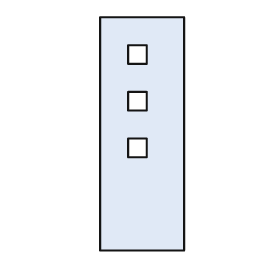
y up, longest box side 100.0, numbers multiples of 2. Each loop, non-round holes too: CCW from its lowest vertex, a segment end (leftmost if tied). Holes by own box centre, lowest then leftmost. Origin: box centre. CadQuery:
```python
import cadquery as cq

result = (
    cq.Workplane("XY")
    .moveTo(-18.0, -50.0)
    .lineTo(18.0, -50.0)
    .lineTo(18.0, 50.0)
    .lineTo(-18.0, 50.0)
    .close()
    .moveTo(-6.0, -10.0)
    .lineTo(2.0, -10.0)
    .lineTo(2.0, -2.0)
    .lineTo(-6.0, -2.0)
    .close()
    .moveTo(-6.0, 10.0)
    .lineTo(2.0, 10.0)
    .lineTo(2.0, 18.0)
    .lineTo(-6.0, 18.0)
    .close()
    .moveTo(-6.0, 30.0)
    .lineTo(2.0, 30.0)
    .lineTo(2.0, 38.0)
    .lineTo(-6.0, 38.0)
    .close()
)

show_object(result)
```